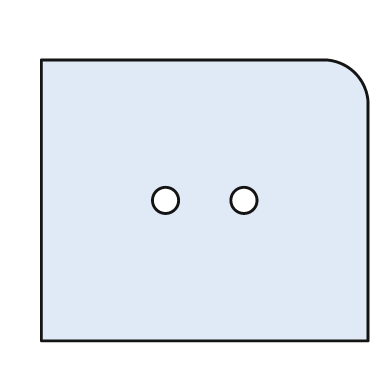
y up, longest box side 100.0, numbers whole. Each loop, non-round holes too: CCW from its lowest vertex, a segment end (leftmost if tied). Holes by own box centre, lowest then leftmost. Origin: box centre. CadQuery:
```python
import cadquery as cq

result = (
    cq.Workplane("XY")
    .moveTo(-50.0, -43.0)
    .lineTo(50.0, -43.0)
    .lineTo(50.0, 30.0)
    .threePointArc((46.0, 39.0), (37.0, 43.0))
    .lineTo(-50.0, 43.0)
    .close()
    .moveTo(-12.0, 0.0)
    .circle(4.0)
    .moveTo(12.0, 0.0)
    .circle(4.0)
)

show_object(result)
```